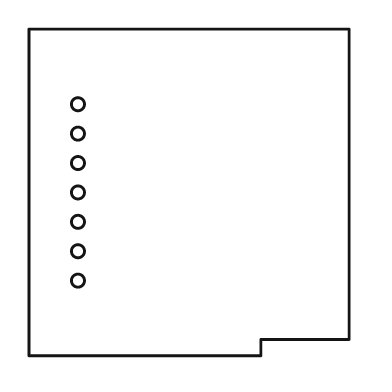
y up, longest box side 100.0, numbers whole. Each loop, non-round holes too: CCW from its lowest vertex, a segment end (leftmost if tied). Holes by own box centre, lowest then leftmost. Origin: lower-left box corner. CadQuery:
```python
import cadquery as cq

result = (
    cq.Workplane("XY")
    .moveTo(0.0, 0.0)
    .lineTo(71.0, 0.0)
    .lineTo(71.0, 5.0)
    .lineTo(98.0, 5.0)
    .lineTo(98.0, 100.0)
    .lineTo(0.0, 100.0)
    .close()
    .moveTo(15.0, 23.0)
    .circle(2.0)
    .moveTo(15.0, 32.0)
    .circle(2.0)
    .moveTo(15.0, 41.0)
    .circle(2.0)
    .moveTo(15.0, 50.0)
    .circle(2.0)
    .moveTo(15.0, 59.0)
    .circle(2.0)
    .moveTo(15.0, 68.0)
    .circle(2.0)
    .moveTo(15.0, 77.0)
    .circle(2.0)
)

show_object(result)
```